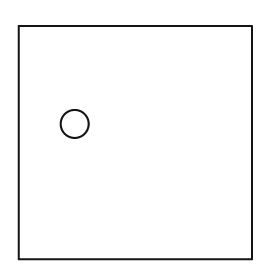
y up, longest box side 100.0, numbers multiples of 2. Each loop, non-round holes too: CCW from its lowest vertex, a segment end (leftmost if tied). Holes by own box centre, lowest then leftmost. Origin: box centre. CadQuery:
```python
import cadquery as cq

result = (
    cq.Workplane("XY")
    .moveTo(-50.0, -50.0)
    .lineTo(50.0, -50.0)
    .lineTo(50.0, 50.0)
    .lineTo(-50.0, 50.0)
    .close()
    .moveTo(-26.0, 8.0)
    .circle(6.0)
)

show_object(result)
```